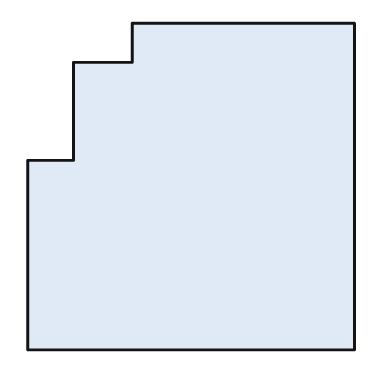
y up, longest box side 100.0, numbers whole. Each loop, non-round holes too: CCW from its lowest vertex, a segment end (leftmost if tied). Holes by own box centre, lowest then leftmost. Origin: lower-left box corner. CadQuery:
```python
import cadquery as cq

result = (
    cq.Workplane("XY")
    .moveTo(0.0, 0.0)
    .lineTo(100.0, 0.0)
    .lineTo(100.0, 100.0)
    .lineTo(32.0, 100.0)
    .lineTo(32.0, 88.0)
    .lineTo(14.0, 88.0)
    .lineTo(14.0, 58.0)
    .lineTo(0.0, 58.0)
    .close()
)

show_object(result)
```